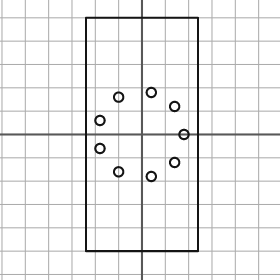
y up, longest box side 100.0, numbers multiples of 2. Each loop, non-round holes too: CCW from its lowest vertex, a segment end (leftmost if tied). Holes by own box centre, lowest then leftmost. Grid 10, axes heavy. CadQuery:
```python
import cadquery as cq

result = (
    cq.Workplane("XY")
    .moveTo(-24.0, -50.0)
    .lineTo(24.0, -50.0)
    .lineTo(24.0, 50.0)
    .lineTo(-24.0, 50.0)
    .close()
    .moveTo(4.0, -18.0)
    .circle(2.0)
    .moveTo(-10.0, -16.0)
    .circle(2.0)
    .moveTo(14.0, -12.0)
    .circle(2.0)
    .moveTo(-18.0, -6.0)
    .circle(2.0)
    .moveTo(18.0, 0.0)
    .circle(2.0)
    .moveTo(-18.0, 6.0)
    .circle(2.0)
    .moveTo(14.0, 12.0)
    .circle(2.0)
    .moveTo(-10.0, 16.0)
    .circle(2.0)
    .moveTo(4.0, 18.0)
    .circle(2.0)
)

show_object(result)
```